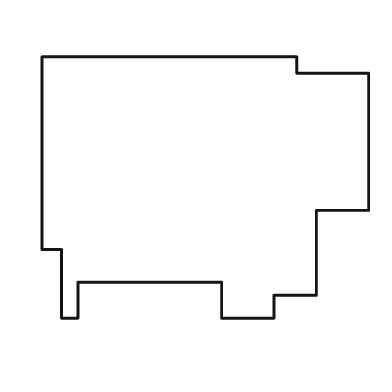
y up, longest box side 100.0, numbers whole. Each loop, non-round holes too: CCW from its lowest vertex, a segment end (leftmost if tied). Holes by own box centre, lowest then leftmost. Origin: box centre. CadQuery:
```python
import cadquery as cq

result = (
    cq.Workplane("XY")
    .moveTo(-44.0, -40.0)
    .lineTo(-39.0, -40.0)
    .lineTo(-39.0, -29.0)
    .lineTo(5.0, -29.0)
    .lineTo(5.0, -40.0)
    .lineTo(21.0, -40.0)
    .lineTo(21.0, -33.0)
    .lineTo(34.0, -33.0)
    .lineTo(34.0, -7.0)
    .lineTo(50.0, -7.0)
    .lineTo(50.0, 35.0)
    .lineTo(28.0, 35.0)
    .lineTo(28.0, 40.0)
    .lineTo(-50.0, 40.0)
    .lineTo(-50.0, -19.0)
    .lineTo(-44.0, -19.0)
    .close()
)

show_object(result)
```